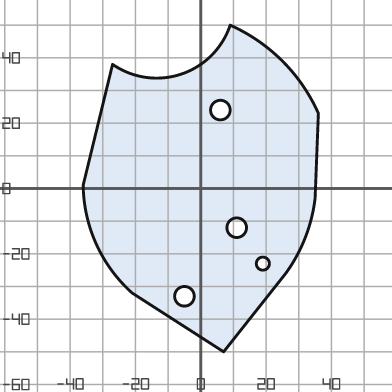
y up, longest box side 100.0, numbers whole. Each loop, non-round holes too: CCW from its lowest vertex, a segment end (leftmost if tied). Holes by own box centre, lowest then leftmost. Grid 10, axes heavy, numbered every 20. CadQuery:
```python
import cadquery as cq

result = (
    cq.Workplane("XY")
    .moveTo(7.0, -50.0)
    .lineTo(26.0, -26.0)
    .threePointArc((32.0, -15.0), (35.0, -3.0))
    .lineTo(36.0, 23.0)
    .threePointArc((25.0, 39.0), (9.0, 50.0))
    .threePointArc((-6.0, 35.0), (-27.0, 38.0))
    .lineTo(-36.0, 1.0)
    .threePointArc((-32.0, -17.0), (-21.0, -32.0))
    .close()
    .moveTo(-5.0, -33.0)
    .circle(3.0)
    .moveTo(19.0, -23.0)
    .circle(2.0)
    .moveTo(11.0, -12.0)
    .circle(3.0)
    .moveTo(6.0, 24.0)
    .circle(3.0)
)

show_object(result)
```